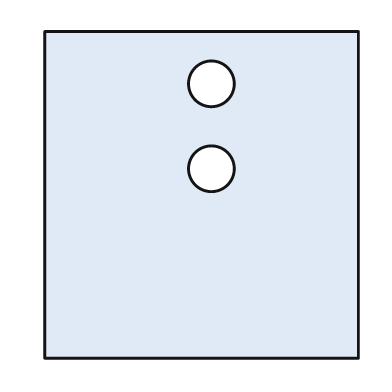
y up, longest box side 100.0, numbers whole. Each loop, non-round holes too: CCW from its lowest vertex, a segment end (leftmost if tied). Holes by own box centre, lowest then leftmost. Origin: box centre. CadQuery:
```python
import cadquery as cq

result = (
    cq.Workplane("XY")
    .moveTo(-48.0, -50.0)
    .lineTo(48.0, -50.0)
    .lineTo(48.0, 50.0)
    .lineTo(-48.0, 50.0)
    .close()
    .moveTo(3.0, 8.0)
    .circle(7.0)
    .moveTo(3.0, 34.0)
    .circle(7.0)
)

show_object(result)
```